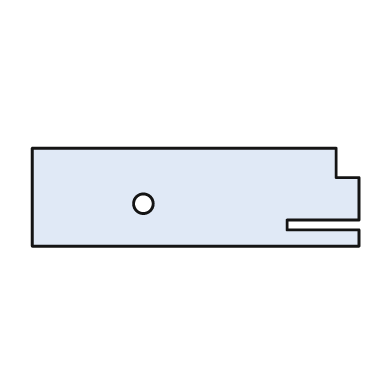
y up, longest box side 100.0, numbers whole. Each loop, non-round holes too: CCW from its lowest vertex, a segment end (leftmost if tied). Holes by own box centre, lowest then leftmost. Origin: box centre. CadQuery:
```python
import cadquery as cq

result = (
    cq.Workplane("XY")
    .moveTo(-50.0, -15.0)
    .lineTo(50.0, -15.0)
    .lineTo(50.0, -10.0)
    .lineTo(28.0, -10.0)
    .lineTo(28.0, -7.0)
    .lineTo(50.0, -7.0)
    .lineTo(50.0, 6.0)
    .lineTo(43.0, 6.0)
    .lineTo(43.0, 15.0)
    .lineTo(-50.0, 15.0)
    .close()
    .moveTo(-16.0, -2.0)
    .circle(3.0)
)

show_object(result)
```